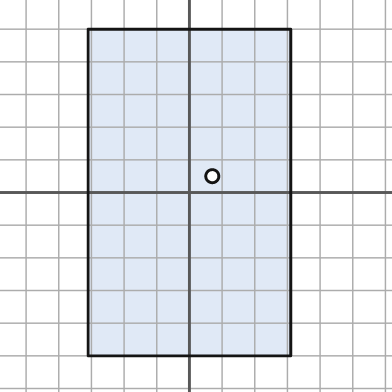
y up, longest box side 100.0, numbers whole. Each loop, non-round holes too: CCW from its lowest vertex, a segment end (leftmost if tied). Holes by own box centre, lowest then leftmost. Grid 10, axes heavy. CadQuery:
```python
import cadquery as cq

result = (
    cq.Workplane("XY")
    .moveTo(-31.0, -50.0)
    .lineTo(31.0, -50.0)
    .lineTo(31.0, 50.0)
    .lineTo(-31.0, 50.0)
    .close()
    .moveTo(7.0, 5.0)
    .circle(2.0)
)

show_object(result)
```